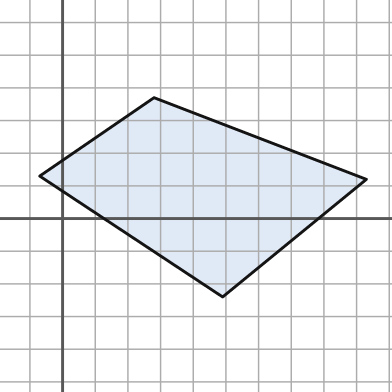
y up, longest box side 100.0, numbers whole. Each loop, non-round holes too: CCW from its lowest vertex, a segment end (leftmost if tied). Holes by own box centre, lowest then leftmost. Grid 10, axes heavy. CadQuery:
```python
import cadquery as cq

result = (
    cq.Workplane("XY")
    .moveTo(49.0, -24.0)
    .lineTo(93.0, 12.0)
    .lineTo(28.0, 37.0)
    .lineTo(-7.0, 13.0)
    .close()
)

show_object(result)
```